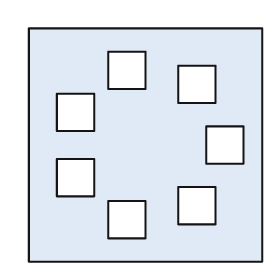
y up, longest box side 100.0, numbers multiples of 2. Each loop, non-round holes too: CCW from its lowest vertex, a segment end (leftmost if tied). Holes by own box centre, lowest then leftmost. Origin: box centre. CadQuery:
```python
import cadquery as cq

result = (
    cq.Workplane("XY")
    .moveTo(-50.0, -50.0)
    .lineTo(50.0, -50.0)
    .lineTo(50.0, 50.0)
    .lineTo(-50.0, 50.0)
    .close()
    .moveTo(-16.0, -40.0)
    .lineTo(0.0, -40.0)
    .lineTo(0.0, -24.0)
    .lineTo(-16.0, -24.0)
    .close()
    .moveTo(14.0, -34.0)
    .lineTo(30.0, -34.0)
    .lineTo(30.0, -18.0)
    .lineTo(14.0, -18.0)
    .close()
    .moveTo(-38.0, -22.0)
    .lineTo(-22.0, -22.0)
    .lineTo(-22.0, -6.0)
    .lineTo(-38.0, -6.0)
    .close()
    .moveTo(26.0, -8.0)
    .lineTo(42.0, -8.0)
    .lineTo(42.0, 8.0)
    .lineTo(26.0, 8.0)
    .close()
    .moveTo(-38.0, 6.0)
    .lineTo(-22.0, 6.0)
    .lineTo(-22.0, 22.0)
    .lineTo(-38.0, 22.0)
    .close()
    .moveTo(14.0, 18.0)
    .lineTo(30.0, 18.0)
    .lineTo(30.0, 34.0)
    .lineTo(14.0, 34.0)
    .close()
    .moveTo(-16.0, 24.0)
    .lineTo(0.0, 24.0)
    .lineTo(0.0, 40.0)
    .lineTo(-16.0, 40.0)
    .close()
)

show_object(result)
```